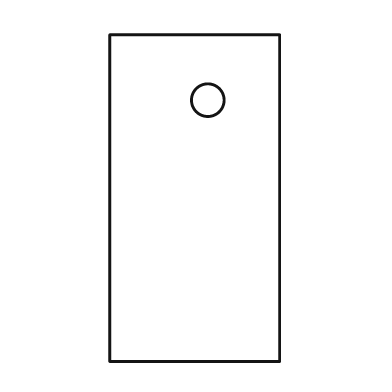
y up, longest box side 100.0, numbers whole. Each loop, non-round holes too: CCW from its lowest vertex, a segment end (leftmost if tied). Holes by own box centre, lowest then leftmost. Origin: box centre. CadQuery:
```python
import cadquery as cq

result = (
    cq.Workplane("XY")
    .moveTo(-26.0, -50.0)
    .lineTo(26.0, -50.0)
    .lineTo(26.0, 50.0)
    .lineTo(-26.0, 50.0)
    .close()
    .moveTo(4.0, 30.0)
    .circle(5.0)
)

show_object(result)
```